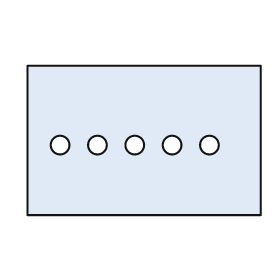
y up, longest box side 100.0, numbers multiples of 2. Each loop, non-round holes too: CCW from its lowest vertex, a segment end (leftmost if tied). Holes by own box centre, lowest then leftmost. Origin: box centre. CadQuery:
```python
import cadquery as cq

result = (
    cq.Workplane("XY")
    .moveTo(-50.0, -32.0)
    .lineTo(50.0, -32.0)
    .lineTo(50.0, 32.0)
    .lineTo(-50.0, 32.0)
    .close()
    .moveTo(-36.0, -2.0)
    .circle(4.0)
    .moveTo(-20.0, -2.0)
    .circle(4.0)
    .moveTo(-4.0, -2.0)
    .circle(4.0)
    .moveTo(12.0, -2.0)
    .circle(4.0)
    .moveTo(28.0, -2.0)
    .circle(4.0)
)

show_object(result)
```